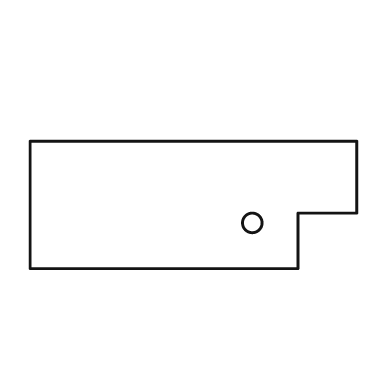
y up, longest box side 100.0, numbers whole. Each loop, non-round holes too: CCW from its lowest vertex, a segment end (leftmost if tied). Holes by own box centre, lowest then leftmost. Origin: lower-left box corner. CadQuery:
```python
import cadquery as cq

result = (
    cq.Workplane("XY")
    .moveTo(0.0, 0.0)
    .lineTo(82.0, 0.0)
    .lineTo(82.0, 17.0)
    .lineTo(100.0, 17.0)
    .lineTo(100.0, 39.0)
    .lineTo(0.0, 39.0)
    .close()
    .moveTo(68.0, 14.0)
    .circle(3.0)
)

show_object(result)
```